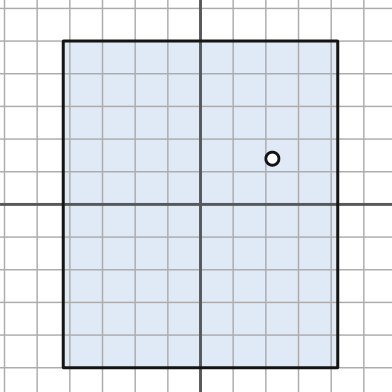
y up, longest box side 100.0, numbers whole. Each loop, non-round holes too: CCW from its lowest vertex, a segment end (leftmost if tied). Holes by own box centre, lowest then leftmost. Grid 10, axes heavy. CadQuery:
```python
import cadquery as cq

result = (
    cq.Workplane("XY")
    .moveTo(-42.0, -50.0)
    .lineTo(42.0, -50.0)
    .lineTo(42.0, 50.0)
    .lineTo(-42.0, 50.0)
    .close()
    .moveTo(22.0, 14.0)
    .circle(2.0)
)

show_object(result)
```